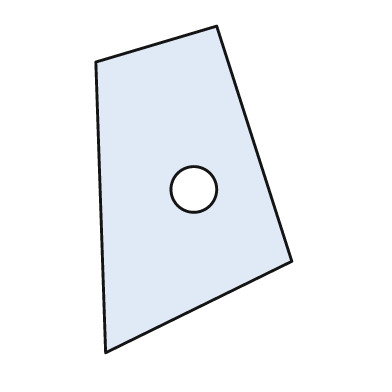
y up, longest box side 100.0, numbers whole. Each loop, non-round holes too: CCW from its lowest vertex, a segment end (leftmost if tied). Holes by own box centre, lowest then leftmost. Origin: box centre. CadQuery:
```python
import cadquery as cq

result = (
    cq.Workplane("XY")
    .moveTo(-27.0, -50.0)
    .lineTo(30.0, -22.0)
    .lineTo(7.0, 50.0)
    .lineTo(-30.0, 39.0)
    .close()
    .moveTo(0.0, 0.0)
    .circle(7.0)
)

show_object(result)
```